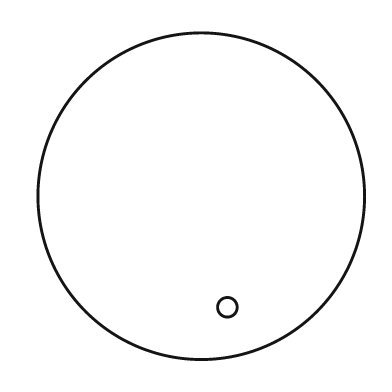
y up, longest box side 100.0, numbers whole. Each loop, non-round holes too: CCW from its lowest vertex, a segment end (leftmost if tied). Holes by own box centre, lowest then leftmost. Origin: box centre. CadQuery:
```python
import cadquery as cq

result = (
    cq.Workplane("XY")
    .moveTo(0.0, 0.0)
    .circle(50.0)
    .moveTo(8.0, -34.0)
    .circle(3.0)
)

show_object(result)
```